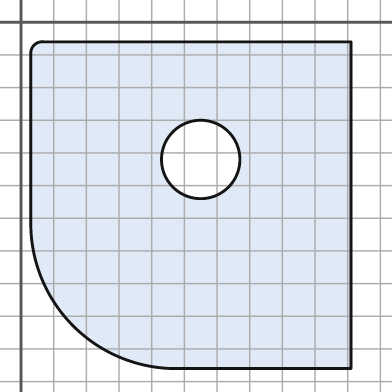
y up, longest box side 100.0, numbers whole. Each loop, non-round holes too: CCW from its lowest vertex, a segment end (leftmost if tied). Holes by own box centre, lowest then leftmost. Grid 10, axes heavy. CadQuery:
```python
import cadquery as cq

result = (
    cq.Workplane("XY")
    .moveTo(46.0, -106.0)
    .lineTo(101.0, -106.0)
    .lineTo(101.0, -6.0)
    .lineTo(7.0, -6.0)
    .threePointArc((4.0, -7.0), (3.0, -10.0))
    .lineTo(3.0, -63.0)
    .threePointArc((16.0, -93.0), (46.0, -106.0))
    .close()
    .moveTo(55.0, -42.0)
    .circle(12.0)
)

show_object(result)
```